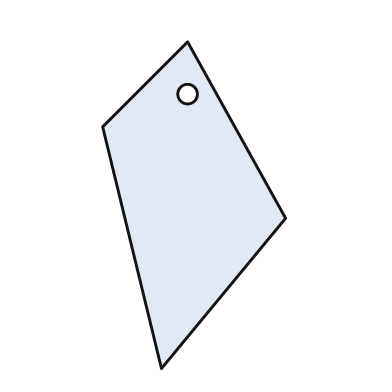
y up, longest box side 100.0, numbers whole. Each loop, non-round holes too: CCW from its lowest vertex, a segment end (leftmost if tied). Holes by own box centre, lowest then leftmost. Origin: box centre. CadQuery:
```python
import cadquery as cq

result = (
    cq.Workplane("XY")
    .moveTo(-10.0, -50.0)
    .lineTo(28.0, -4.0)
    .lineTo(-2.0, 50.0)
    .lineTo(-28.0, 24.0)
    .close()
    .moveTo(-2.0, 34.0)
    .circle(3.0)
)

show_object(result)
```